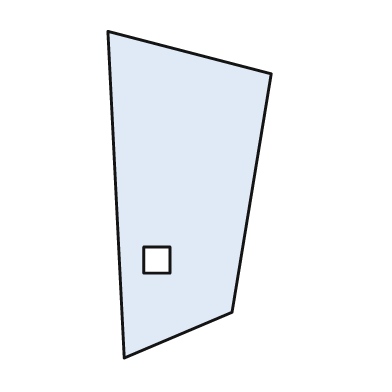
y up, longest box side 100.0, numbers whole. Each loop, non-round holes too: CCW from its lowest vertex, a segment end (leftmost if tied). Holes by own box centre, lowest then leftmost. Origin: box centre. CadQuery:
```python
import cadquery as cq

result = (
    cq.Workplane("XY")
    .moveTo(-20.0, -50.0)
    .lineTo(13.0, -36.0)
    .lineTo(25.0, 37.0)
    .lineTo(-25.0, 50.0)
    .close()
    .moveTo(-14.0, -24.0)
    .lineTo(-6.0, -24.0)
    .lineTo(-6.0, -16.0)
    .lineTo(-14.0, -16.0)
    .close()
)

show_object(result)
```